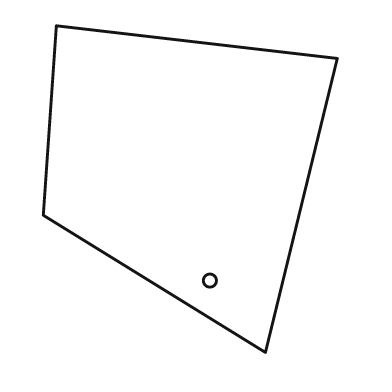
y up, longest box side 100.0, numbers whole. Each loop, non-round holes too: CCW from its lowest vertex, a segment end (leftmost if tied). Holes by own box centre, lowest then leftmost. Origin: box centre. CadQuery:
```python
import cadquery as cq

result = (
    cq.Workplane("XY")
    .moveTo(23.0, -50.0)
    .lineTo(45.0, 40.0)
    .lineTo(-41.0, 50.0)
    .lineTo(-45.0, -8.0)
    .close()
    .moveTo(6.0, -28.0)
    .circle(2.0)
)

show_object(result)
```